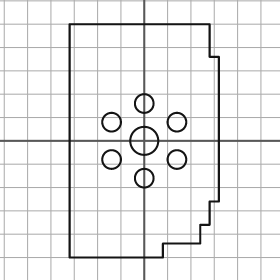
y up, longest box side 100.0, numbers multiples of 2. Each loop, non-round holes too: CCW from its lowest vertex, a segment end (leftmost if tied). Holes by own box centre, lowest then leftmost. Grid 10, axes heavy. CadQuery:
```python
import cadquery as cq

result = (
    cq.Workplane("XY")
    .moveTo(-32.0, -50.0)
    .lineTo(8.0, -50.0)
    .lineTo(8.0, -44.0)
    .lineTo(24.0, -44.0)
    .lineTo(24.0, -36.0)
    .lineTo(28.0, -36.0)
    .lineTo(28.0, -26.0)
    .lineTo(32.0, -26.0)
    .lineTo(32.0, 36.0)
    .lineTo(28.0, 36.0)
    .lineTo(28.0, 50.0)
    .lineTo(-32.0, 50.0)
    .close()
    .moveTo(0.0, -16.0)
    .circle(4.0)
    .moveTo(-14.0, -8.0)
    .circle(4.0)
    .moveTo(14.0, -8.0)
    .circle(4.0)
    .moveTo(0.0, 0.0)
    .circle(6.0)
    .moveTo(-14.0, 8.0)
    .circle(4.0)
    .moveTo(14.0, 8.0)
    .circle(4.0)
    .moveTo(0.0, 16.0)
    .circle(4.0)
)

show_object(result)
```